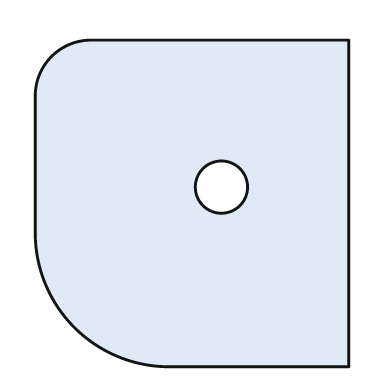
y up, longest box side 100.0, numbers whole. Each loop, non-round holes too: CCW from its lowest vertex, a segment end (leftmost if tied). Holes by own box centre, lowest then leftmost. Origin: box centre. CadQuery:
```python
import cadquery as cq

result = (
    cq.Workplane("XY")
    .moveTo(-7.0, -50.0)
    .lineTo(48.0, -50.0)
    .lineTo(48.0, 50.0)
    .lineTo(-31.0, 50.0)
    .threePointArc((-43.0, 45.0), (-48.0, 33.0))
    .lineTo(-48.0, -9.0)
    .threePointArc((-36.0, -38.0), (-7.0, -50.0))
    .close()
    .moveTo(9.0, 5.0)
    .circle(8.0)
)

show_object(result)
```